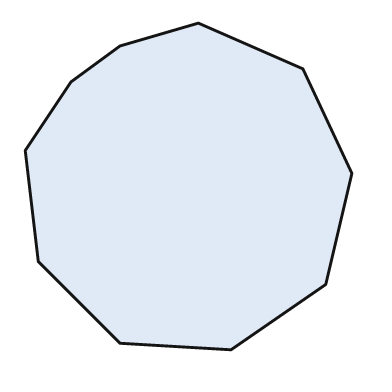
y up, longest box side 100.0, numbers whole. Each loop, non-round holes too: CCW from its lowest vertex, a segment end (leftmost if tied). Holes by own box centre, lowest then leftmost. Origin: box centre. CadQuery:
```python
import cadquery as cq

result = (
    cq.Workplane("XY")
    .moveTo(13.0, -50.0)
    .lineTo(42.0, -30.0)
    .lineTo(50.0, 4.0)
    .lineTo(35.0, 36.0)
    .lineTo(3.0, 50.0)
    .lineTo(-21.0, 43.0)
    .lineTo(-36.0, 32.0)
    .lineTo(-50.0, 11.0)
    .lineTo(-46.0, -23.0)
    .lineTo(-21.0, -48.0)
    .close()
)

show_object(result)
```